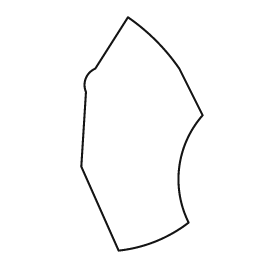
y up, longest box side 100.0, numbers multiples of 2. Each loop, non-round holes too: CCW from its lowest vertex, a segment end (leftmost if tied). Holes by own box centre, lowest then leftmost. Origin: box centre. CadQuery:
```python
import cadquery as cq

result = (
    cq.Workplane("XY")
    .moveTo(-10.0, -50.0)
    .threePointArc((6.0, -46.0), (20.0, -38.0))
    .threePointArc((16.0, -14.0), (26.0, 8.0))
    .lineTo(16.0, 28.0)
    .threePointArc((6.0, 40.0), (-6.0, 50.0))
    .lineTo(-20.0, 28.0)
    .threePointArc((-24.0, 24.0), (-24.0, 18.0))
    .lineTo(-26.0, -14.0)
    .close()
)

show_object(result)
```